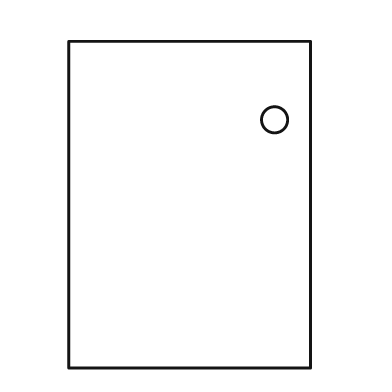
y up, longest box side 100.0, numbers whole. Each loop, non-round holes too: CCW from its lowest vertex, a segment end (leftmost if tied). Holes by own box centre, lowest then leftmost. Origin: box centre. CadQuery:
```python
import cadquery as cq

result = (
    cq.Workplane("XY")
    .moveTo(-37.0, -50.0)
    .lineTo(37.0, -50.0)
    .lineTo(37.0, 50.0)
    .lineTo(-37.0, 50.0)
    .close()
    .moveTo(26.0, 26.0)
    .circle(4.0)
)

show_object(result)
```